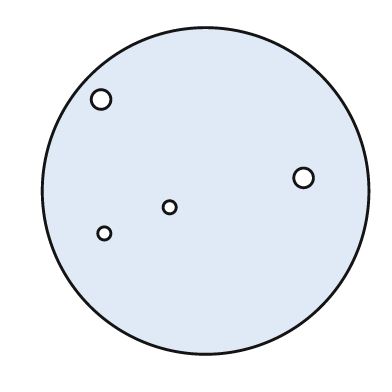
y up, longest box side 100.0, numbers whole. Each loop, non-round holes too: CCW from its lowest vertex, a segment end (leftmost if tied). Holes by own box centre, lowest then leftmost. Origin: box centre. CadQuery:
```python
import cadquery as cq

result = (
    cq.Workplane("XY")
    .moveTo(0.0, 0.0)
    .circle(50.0)
    .moveTo(-31.0, -13.0)
    .circle(2.0)
    .moveTo(-11.0, -5.0)
    .circle(2.0)
    .moveTo(30.0, 4.0)
    .circle(3.0)
    .moveTo(-32.0, 28.0)
    .circle(3.0)
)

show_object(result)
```